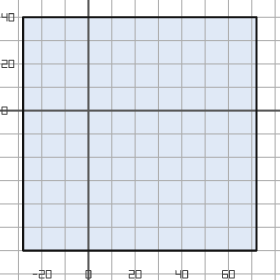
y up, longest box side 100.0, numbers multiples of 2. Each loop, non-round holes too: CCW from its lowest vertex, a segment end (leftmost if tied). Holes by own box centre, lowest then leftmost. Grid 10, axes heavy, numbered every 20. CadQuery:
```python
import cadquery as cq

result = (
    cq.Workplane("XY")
    .moveTo(-28.0, -60.0)
    .lineTo(72.0, -60.0)
    .lineTo(72.0, 40.0)
    .lineTo(-28.0, 40.0)
    .close()
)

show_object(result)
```